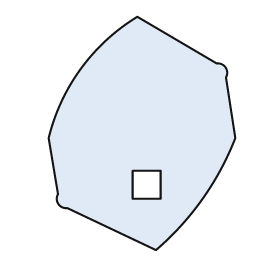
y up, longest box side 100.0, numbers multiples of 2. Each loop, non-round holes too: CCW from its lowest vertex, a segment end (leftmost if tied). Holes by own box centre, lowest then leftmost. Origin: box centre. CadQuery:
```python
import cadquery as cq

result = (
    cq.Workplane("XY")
    .moveTo(6.0, -50.0)
    .threePointArc((26.0, -28.0), (40.0, -2.0))
    .lineTo(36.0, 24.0)
    .threePointArc((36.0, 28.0), (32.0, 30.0))
    .lineTo(-2.0, 50.0)
    .threePointArc((-26.0, 28.0), (-40.0, -2.0))
    .lineTo(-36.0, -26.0)
    .threePointArc((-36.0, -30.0), (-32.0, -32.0))
    .close()
    .moveTo(-4.0, -28.0)
    .lineTo(8.0, -28.0)
    .lineTo(8.0, -16.0)
    .lineTo(-4.0, -16.0)
    .close()
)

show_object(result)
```